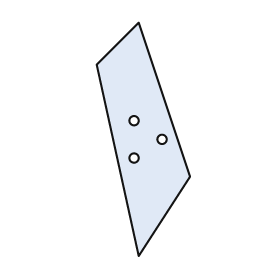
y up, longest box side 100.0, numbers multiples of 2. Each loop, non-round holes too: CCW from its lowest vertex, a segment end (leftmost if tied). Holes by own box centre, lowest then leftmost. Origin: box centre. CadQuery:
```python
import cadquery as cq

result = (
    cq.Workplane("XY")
    .moveTo(-2.0, -50.0)
    .lineTo(20.0, -16.0)
    .lineTo(-2.0, 50.0)
    .lineTo(-20.0, 32.0)
    .close()
    .moveTo(-4.0, -8.0)
    .circle(2.0)
    .moveTo(8.0, 0.0)
    .circle(2.0)
    .moveTo(-4.0, 8.0)
    .circle(2.0)
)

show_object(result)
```